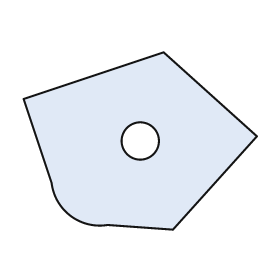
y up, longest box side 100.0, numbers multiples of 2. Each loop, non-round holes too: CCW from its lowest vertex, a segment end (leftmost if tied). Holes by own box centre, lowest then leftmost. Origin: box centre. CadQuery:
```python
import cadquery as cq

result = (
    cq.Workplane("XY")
    .moveTo(14.0, -38.0)
    .lineTo(50.0, 2.0)
    .lineTo(10.0, 38.0)
    .lineTo(-50.0, 18.0)
    .lineTo(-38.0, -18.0)
    .threePointArc((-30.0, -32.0), (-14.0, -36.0))
    .close()
    .moveTo(0.0, 0.0)
    .circle(8.0)
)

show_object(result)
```